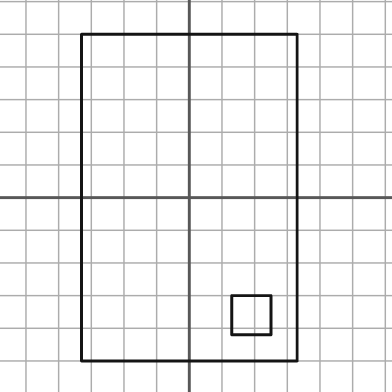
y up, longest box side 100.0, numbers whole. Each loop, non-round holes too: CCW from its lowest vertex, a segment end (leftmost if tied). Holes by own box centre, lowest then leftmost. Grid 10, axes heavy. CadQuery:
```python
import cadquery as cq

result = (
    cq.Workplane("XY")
    .moveTo(-33.0, -50.0)
    .lineTo(33.0, -50.0)
    .lineTo(33.0, 50.0)
    .lineTo(-33.0, 50.0)
    .close()
    .moveTo(13.0, -42.0)
    .lineTo(25.0, -42.0)
    .lineTo(25.0, -30.0)
    .lineTo(13.0, -30.0)
    .close()
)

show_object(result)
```